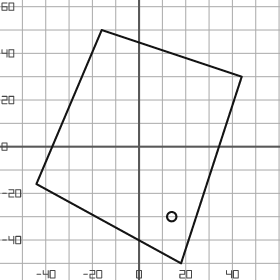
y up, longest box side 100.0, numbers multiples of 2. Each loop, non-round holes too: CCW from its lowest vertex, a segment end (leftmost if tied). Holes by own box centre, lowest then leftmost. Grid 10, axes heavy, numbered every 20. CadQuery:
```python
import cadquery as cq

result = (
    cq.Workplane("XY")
    .moveTo(18.0, -50.0)
    .lineTo(44.0, 30.0)
    .lineTo(-16.0, 50.0)
    .lineTo(-44.0, -16.0)
    .close()
    .moveTo(14.0, -30.0)
    .circle(2.0)
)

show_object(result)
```